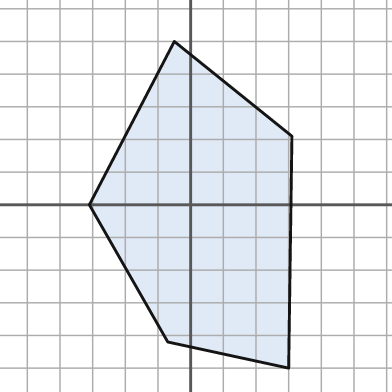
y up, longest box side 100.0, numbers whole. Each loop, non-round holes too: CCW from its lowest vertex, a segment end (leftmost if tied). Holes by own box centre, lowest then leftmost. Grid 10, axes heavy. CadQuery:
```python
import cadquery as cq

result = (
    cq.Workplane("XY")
    .moveTo(30.0, -50.0)
    .lineTo(31.0, 21.0)
    .lineTo(-5.0, 50.0)
    .lineTo(-31.0, 0.0)
    .lineTo(-7.0, -42.0)
    .close()
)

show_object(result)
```